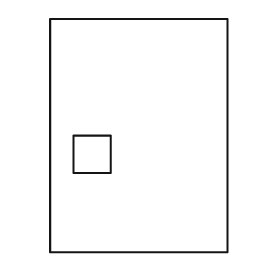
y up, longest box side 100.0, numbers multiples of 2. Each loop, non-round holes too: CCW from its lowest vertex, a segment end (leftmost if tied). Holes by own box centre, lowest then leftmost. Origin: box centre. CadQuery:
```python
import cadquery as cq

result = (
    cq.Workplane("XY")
    .moveTo(-38.0, -50.0)
    .lineTo(38.0, -50.0)
    .lineTo(38.0, 50.0)
    .lineTo(-38.0, 50.0)
    .close()
    .moveTo(-28.0, -16.0)
    .lineTo(-12.0, -16.0)
    .lineTo(-12.0, 0.0)
    .lineTo(-28.0, 0.0)
    .close()
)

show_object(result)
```